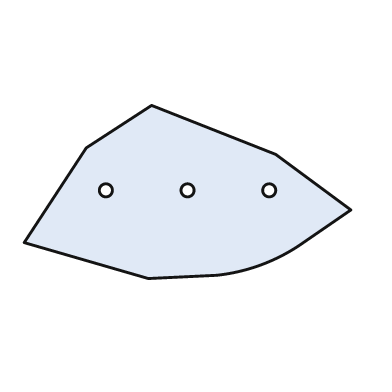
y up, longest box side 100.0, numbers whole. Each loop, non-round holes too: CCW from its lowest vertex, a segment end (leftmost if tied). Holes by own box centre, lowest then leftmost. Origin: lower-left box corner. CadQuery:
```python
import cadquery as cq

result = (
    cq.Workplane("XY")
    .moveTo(38.0, 0.0)
    .lineTo(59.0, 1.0)
    .threePointArc((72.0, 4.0), (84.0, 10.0))
    .lineTo(100.0, 21.0)
    .lineTo(77.0, 38.0)
    .lineTo(39.0, 53.0)
    .lineTo(19.0, 40.0)
    .lineTo(0.0, 11.0)
    .close()
    .moveTo(25.0, 27.0)
    .circle(2.0)
    .moveTo(50.0, 27.0)
    .circle(2.0)
    .moveTo(75.0, 27.0)
    .circle(2.0)
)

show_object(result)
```